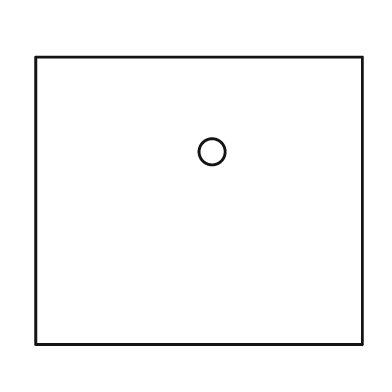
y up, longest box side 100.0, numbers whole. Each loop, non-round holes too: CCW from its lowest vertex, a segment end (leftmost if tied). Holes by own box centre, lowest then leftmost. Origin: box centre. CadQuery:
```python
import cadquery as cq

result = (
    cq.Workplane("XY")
    .moveTo(-50.0, -44.0)
    .lineTo(50.0, -44.0)
    .lineTo(50.0, 44.0)
    .lineTo(-50.0, 44.0)
    .close()
    .moveTo(4.0, 15.0)
    .circle(4.0)
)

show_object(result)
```